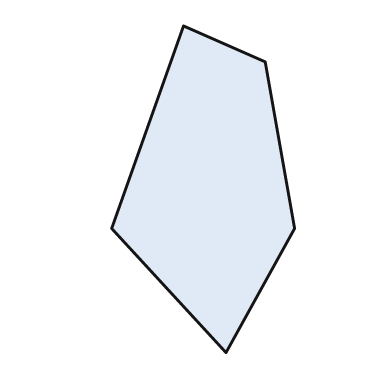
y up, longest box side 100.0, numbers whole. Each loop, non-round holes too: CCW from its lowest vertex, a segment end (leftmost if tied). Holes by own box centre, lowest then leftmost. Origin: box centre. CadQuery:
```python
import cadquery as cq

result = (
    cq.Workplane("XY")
    .moveTo(7.0, -50.0)
    .lineTo(28.0, -12.0)
    .lineTo(19.0, 39.0)
    .lineTo(-6.0, 50.0)
    .lineTo(-28.0, -12.0)
    .close()
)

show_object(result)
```